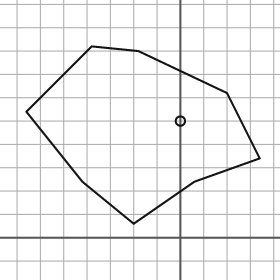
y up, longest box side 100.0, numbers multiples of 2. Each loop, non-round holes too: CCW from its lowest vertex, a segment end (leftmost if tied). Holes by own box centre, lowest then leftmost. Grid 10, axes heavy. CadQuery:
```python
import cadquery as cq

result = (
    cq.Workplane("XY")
    .moveTo(-20.0, 6.0)
    .lineTo(6.0, 24.0)
    .lineTo(34.0, 34.0)
    .lineTo(20.0, 62.0)
    .lineTo(-18.0, 80.0)
    .lineTo(-38.0, 82.0)
    .lineTo(-66.0, 54.0)
    .lineTo(-42.0, 24.0)
    .close()
    .moveTo(0.0, 50.0)
    .circle(2.0)
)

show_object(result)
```